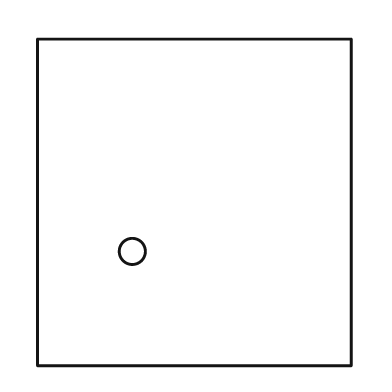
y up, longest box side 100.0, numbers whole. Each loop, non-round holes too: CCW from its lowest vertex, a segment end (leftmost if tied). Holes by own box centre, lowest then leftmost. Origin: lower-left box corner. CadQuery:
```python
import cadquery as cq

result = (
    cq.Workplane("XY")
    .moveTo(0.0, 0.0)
    .lineTo(96.0, 0.0)
    .lineTo(96.0, 100.0)
    .lineTo(0.0, 100.0)
    .close()
    .moveTo(29.0, 35.0)
    .circle(4.0)
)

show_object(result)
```